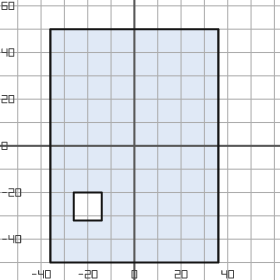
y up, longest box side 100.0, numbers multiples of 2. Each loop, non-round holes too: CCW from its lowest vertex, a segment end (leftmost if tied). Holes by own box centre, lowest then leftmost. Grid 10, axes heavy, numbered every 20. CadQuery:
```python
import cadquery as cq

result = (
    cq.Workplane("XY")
    .moveTo(-36.0, -50.0)
    .lineTo(36.0, -50.0)
    .lineTo(36.0, 50.0)
    .lineTo(-36.0, 50.0)
    .close()
    .moveTo(-26.0, -32.0)
    .lineTo(-14.0, -32.0)
    .lineTo(-14.0, -20.0)
    .lineTo(-26.0, -20.0)
    .close()
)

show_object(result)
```